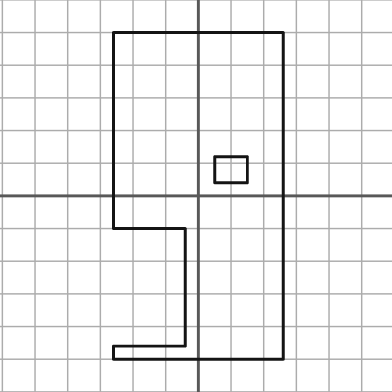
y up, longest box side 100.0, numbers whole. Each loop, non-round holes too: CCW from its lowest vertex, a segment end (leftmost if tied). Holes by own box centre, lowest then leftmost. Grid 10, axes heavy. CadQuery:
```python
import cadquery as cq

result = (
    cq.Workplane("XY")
    .moveTo(-26.0, -50.0)
    .lineTo(26.0, -50.0)
    .lineTo(26.0, 50.0)
    .lineTo(-26.0, 50.0)
    .lineTo(-26.0, -10.0)
    .lineTo(-4.0, -10.0)
    .lineTo(-4.0, -46.0)
    .lineTo(-26.0, -46.0)
    .close()
    .moveTo(5.0, 4.0)
    .lineTo(15.0, 4.0)
    .lineTo(15.0, 12.0)
    .lineTo(5.0, 12.0)
    .close()
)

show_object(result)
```